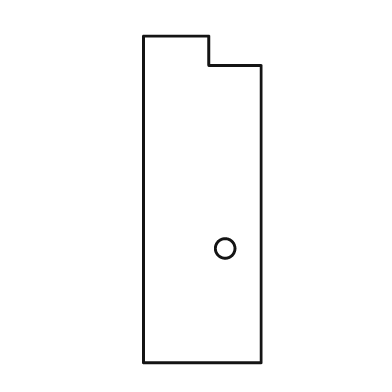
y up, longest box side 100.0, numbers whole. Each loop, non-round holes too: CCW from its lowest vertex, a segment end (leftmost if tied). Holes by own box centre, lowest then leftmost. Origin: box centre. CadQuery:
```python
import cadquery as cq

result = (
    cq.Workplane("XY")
    .moveTo(-18.0, -50.0)
    .lineTo(18.0, -50.0)
    .lineTo(18.0, 41.0)
    .lineTo(2.0, 41.0)
    .lineTo(2.0, 50.0)
    .lineTo(-18.0, 50.0)
    .close()
    .moveTo(7.0, -15.0)
    .circle(3.0)
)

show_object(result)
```